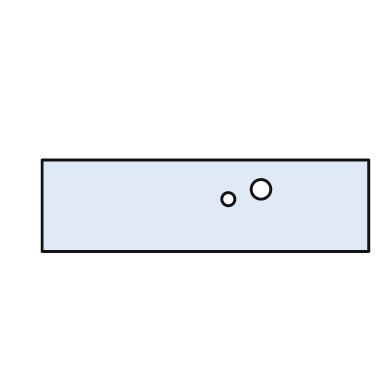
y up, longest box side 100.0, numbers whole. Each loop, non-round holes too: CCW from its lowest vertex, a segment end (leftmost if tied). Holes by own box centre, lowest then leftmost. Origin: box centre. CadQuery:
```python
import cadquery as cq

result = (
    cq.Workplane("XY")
    .moveTo(-50.0, -14.0)
    .lineTo(50.0, -14.0)
    .lineTo(50.0, 14.0)
    .lineTo(-50.0, 14.0)
    .close()
    .moveTo(7.0, 2.0)
    .circle(2.0)
    .moveTo(17.0, 5.0)
    .circle(3.0)
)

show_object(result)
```